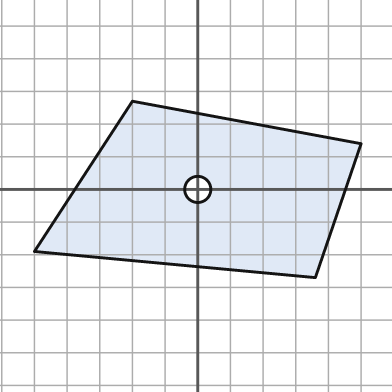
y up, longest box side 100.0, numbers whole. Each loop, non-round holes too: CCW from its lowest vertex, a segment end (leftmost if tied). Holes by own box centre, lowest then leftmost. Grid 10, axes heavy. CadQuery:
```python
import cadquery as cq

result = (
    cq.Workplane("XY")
    .moveTo(36.0, -27.0)
    .lineTo(50.0, 14.0)
    .lineTo(-20.0, 27.0)
    .lineTo(-50.0, -19.0)
    .close()
    .moveTo(0.0, 0.0)
    .circle(4.0)
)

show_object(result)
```